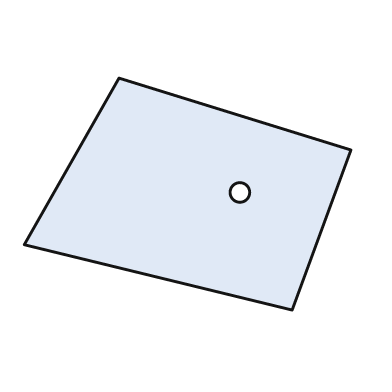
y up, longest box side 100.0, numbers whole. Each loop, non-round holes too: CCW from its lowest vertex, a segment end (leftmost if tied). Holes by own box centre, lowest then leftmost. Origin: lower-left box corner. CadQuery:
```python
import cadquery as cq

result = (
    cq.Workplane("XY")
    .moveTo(82.0, 0.0)
    .lineTo(100.0, 49.0)
    .lineTo(29.0, 71.0)
    .lineTo(0.0, 20.0)
    .close()
    .moveTo(66.0, 36.0)
    .circle(3.0)
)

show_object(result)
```